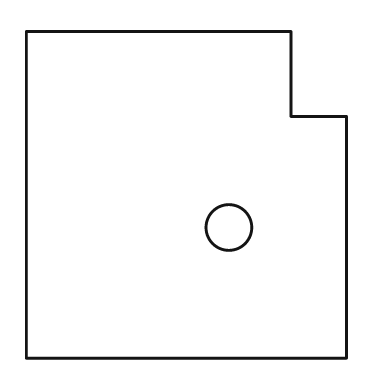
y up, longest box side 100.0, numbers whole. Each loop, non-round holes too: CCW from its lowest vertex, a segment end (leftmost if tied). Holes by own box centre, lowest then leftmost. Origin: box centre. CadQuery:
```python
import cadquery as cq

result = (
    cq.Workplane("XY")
    .moveTo(-49.0, -50.0)
    .lineTo(49.0, -50.0)
    .lineTo(49.0, 24.0)
    .lineTo(32.0, 24.0)
    .lineTo(32.0, 50.0)
    .lineTo(-49.0, 50.0)
    .close()
    .moveTo(13.0, -10.0)
    .circle(7.0)
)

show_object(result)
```